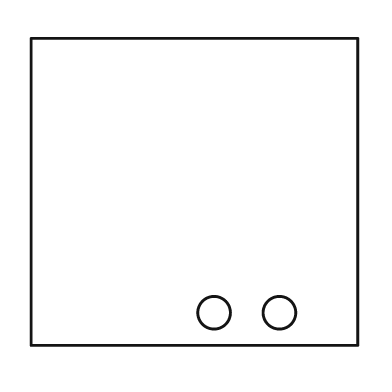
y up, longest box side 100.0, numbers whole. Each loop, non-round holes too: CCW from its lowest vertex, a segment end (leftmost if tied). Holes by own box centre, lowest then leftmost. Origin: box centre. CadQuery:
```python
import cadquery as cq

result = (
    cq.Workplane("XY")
    .moveTo(-50.0, -47.0)
    .lineTo(50.0, -47.0)
    .lineTo(50.0, 47.0)
    .lineTo(-50.0, 47.0)
    .close()
    .moveTo(6.0, -37.0)
    .circle(5.0)
    .moveTo(26.0, -37.0)
    .circle(5.0)
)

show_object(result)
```